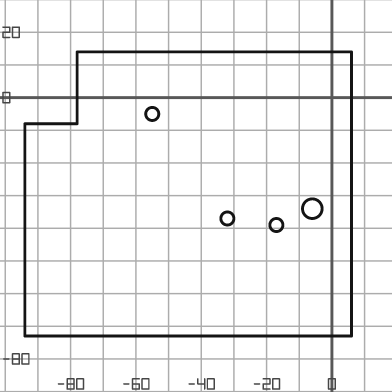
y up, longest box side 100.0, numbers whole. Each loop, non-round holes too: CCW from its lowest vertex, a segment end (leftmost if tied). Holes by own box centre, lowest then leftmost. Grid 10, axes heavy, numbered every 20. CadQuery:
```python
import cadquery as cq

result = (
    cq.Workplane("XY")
    .moveTo(-94.0, -73.0)
    .lineTo(6.0, -73.0)
    .lineTo(6.0, 14.0)
    .lineTo(-78.0, 14.0)
    .lineTo(-78.0, -8.0)
    .lineTo(-94.0, -8.0)
    .close()
    .moveTo(-17.0, -39.0)
    .circle(2.0)
    .moveTo(-32.0, -37.0)
    .circle(2.0)
    .moveTo(-6.0, -34.0)
    .circle(3.0)
    .moveTo(-55.0, -5.0)
    .circle(2.0)
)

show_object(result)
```